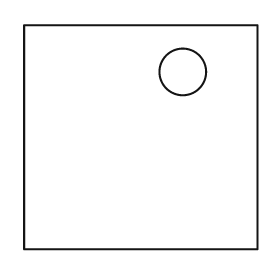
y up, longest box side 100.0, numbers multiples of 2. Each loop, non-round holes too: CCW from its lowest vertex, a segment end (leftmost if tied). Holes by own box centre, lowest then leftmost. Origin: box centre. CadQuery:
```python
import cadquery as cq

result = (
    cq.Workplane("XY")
    .moveTo(-50.0, -48.0)
    .lineTo(50.0, -48.0)
    .lineTo(50.0, 48.0)
    .lineTo(-50.0, 48.0)
    .close()
    .moveTo(18.0, 28.0)
    .circle(10.0)
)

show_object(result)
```